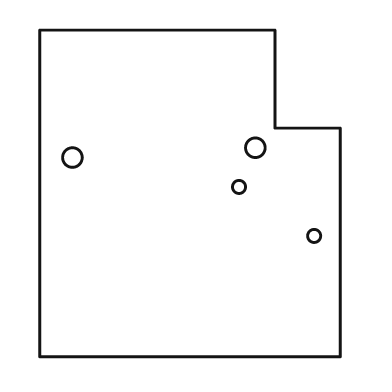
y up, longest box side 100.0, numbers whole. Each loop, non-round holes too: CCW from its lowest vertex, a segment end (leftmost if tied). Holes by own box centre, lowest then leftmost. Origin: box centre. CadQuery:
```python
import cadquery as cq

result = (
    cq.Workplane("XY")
    .moveTo(-46.0, -50.0)
    .lineTo(46.0, -50.0)
    .lineTo(46.0, 20.0)
    .lineTo(26.0, 20.0)
    .lineTo(26.0, 50.0)
    .lineTo(-46.0, 50.0)
    .close()
    .moveTo(38.0, -13.0)
    .circle(2.0)
    .moveTo(15.0, 2.0)
    .circle(2.0)
    .moveTo(-36.0, 11.0)
    .circle(3.0)
    .moveTo(20.0, 14.0)
    .circle(3.0)
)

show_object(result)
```